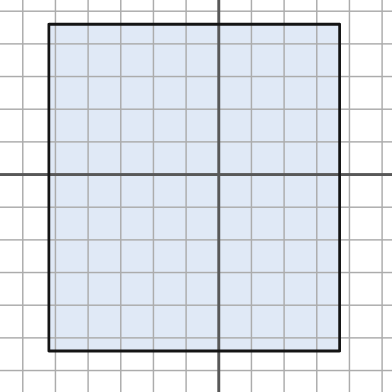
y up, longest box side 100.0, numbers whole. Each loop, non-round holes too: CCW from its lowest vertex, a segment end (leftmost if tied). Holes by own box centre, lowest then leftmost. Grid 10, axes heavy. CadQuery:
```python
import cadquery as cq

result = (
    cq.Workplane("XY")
    .moveTo(-52.0, -54.0)
    .lineTo(37.0, -54.0)
    .lineTo(37.0, 46.0)
    .lineTo(-52.0, 46.0)
    .close()
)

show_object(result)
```